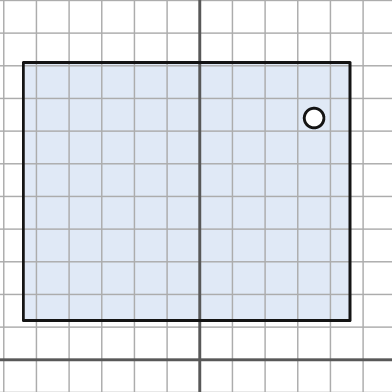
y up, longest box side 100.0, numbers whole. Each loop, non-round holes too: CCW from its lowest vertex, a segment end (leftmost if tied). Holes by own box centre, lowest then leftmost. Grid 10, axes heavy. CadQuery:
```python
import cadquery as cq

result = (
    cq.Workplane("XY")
    .moveTo(-54.0, 12.0)
    .lineTo(46.0, 12.0)
    .lineTo(46.0, 91.0)
    .lineTo(-54.0, 91.0)
    .close()
    .moveTo(35.0, 74.0)
    .circle(3.0)
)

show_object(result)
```